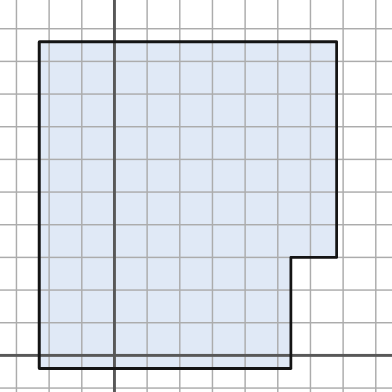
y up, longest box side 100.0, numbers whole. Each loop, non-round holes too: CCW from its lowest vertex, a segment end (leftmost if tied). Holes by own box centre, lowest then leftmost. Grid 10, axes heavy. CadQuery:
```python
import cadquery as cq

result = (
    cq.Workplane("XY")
    .moveTo(-23.0, -4.0)
    .lineTo(54.0, -4.0)
    .lineTo(54.0, 30.0)
    .lineTo(68.0, 30.0)
    .lineTo(68.0, 96.0)
    .lineTo(-23.0, 96.0)
    .close()
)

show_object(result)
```